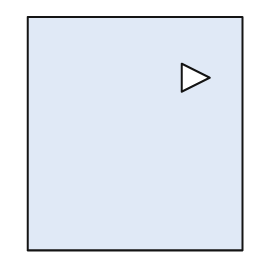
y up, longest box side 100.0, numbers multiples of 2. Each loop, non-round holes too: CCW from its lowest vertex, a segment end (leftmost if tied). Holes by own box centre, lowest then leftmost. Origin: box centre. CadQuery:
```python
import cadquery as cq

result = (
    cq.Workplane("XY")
    .moveTo(-46.0, -50.0)
    .lineTo(46.0, -50.0)
    .lineTo(46.0, 50.0)
    .lineTo(-46.0, 50.0)
    .close()
    .moveTo(20.0, 18.0)
    .lineTo(32.0, 24.0)
    .lineTo(20.0, 30.0)
    .close()
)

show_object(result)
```